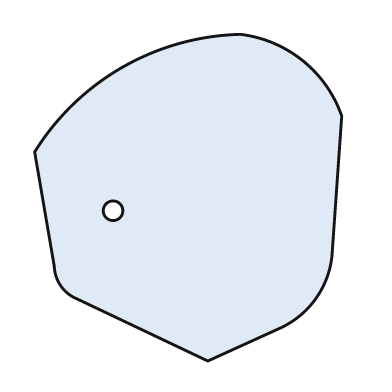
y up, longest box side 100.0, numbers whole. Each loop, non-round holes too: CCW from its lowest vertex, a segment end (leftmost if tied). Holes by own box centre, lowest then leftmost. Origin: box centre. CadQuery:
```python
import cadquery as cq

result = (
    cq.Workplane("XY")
    .moveTo(6.0, -50.0)
    .lineTo(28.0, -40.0)
    .threePointArc((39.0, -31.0), (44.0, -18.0))
    .lineTo(47.0, 25.0)
    .threePointArc((35.0, 42.0), (16.0, 50.0))
    .threePointArc((-20.0, 40.0), (-47.0, 14.0))
    .lineTo(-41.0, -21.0)
    .threePointArc((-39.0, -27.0), (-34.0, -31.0))
    .close()
    .moveTo(-23.0, -4.0)
    .circle(3.0)
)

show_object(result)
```